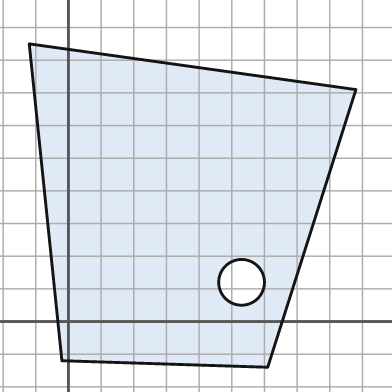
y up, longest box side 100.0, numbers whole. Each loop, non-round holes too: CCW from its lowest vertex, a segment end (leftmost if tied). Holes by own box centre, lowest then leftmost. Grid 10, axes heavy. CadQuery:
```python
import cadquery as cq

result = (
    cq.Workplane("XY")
    .moveTo(61.0, -14.0)
    .lineTo(88.0, 71.0)
    .lineTo(-12.0, 85.0)
    .lineTo(-2.0, -12.0)
    .close()
    .moveTo(53.0, 12.0)
    .circle(7.0)
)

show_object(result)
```